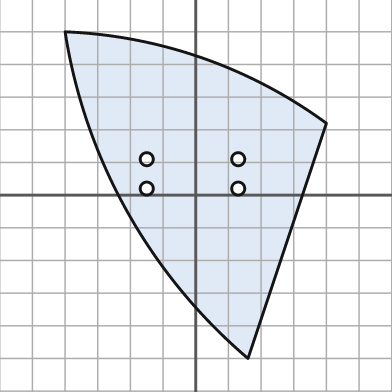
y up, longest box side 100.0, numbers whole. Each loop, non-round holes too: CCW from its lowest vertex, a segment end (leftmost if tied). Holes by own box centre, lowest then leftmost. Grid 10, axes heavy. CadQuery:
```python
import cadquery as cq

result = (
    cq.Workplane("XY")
    .moveTo(16.0, -50.0)
    .lineTo(40.0, 22.0)
    .threePointArc((2.0, 42.0), (-40.0, 50.0))
    .threePointArc((-21.0, -5.0), (16.0, -50.0))
    .close()
    .moveTo(-15.0, 2.0)
    .circle(2.0)
    .moveTo(13.0, 2.0)
    .circle(2.0)
    .moveTo(-15.0, 11.0)
    .circle(2.0)
    .moveTo(13.0, 11.0)
    .circle(2.0)
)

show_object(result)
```